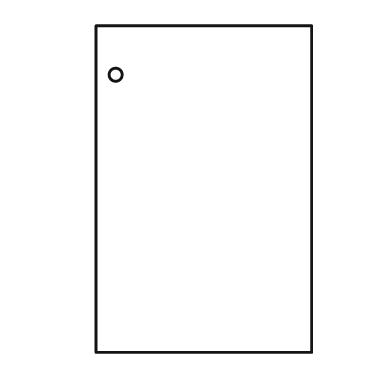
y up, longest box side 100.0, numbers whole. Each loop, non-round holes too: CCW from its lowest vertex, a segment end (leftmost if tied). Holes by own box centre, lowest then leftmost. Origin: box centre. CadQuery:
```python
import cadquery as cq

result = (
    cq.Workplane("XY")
    .moveTo(-33.0, -50.0)
    .lineTo(33.0, -50.0)
    .lineTo(33.0, 50.0)
    .lineTo(-33.0, 50.0)
    .close()
    .moveTo(-27.0, 35.0)
    .circle(2.0)
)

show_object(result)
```